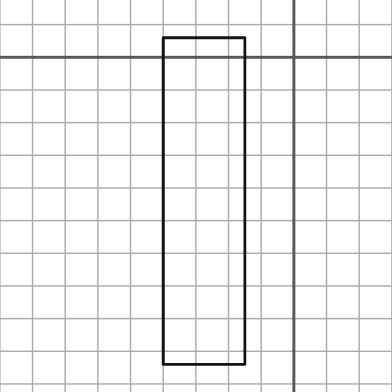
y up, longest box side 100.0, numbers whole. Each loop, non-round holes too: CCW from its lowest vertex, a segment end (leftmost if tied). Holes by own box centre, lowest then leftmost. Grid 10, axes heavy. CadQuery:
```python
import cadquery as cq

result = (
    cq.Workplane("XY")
    .moveTo(-40.0, -94.0)
    .lineTo(-15.0, -94.0)
    .lineTo(-15.0, 6.0)
    .lineTo(-40.0, 6.0)
    .close()
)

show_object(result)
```